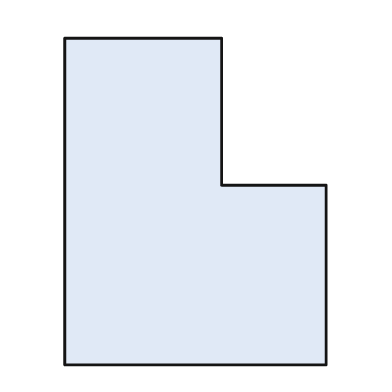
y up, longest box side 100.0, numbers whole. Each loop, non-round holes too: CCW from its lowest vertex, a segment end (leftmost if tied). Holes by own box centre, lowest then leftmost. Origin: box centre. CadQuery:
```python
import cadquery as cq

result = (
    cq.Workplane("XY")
    .moveTo(-40.0, -50.0)
    .lineTo(40.0, -50.0)
    .lineTo(40.0, 5.0)
    .lineTo(8.0, 5.0)
    .lineTo(8.0, 50.0)
    .lineTo(-40.0, 50.0)
    .close()
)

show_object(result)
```